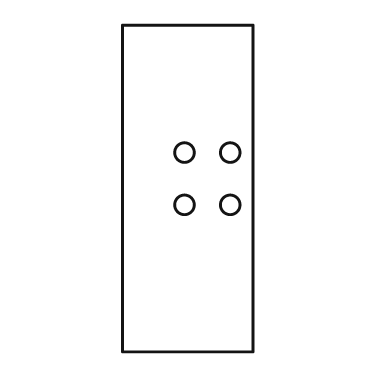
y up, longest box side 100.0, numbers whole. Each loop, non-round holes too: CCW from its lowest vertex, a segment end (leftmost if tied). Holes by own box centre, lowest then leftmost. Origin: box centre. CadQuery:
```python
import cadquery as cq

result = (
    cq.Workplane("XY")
    .moveTo(-20.0, -50.0)
    .lineTo(20.0, -50.0)
    .lineTo(20.0, 50.0)
    .lineTo(-20.0, 50.0)
    .close()
    .moveTo(-1.0, -5.0)
    .circle(3.0)
    .moveTo(13.0, -5.0)
    .circle(3.0)
    .moveTo(-1.0, 11.0)
    .circle(3.0)
    .moveTo(13.0, 11.0)
    .circle(3.0)
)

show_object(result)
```